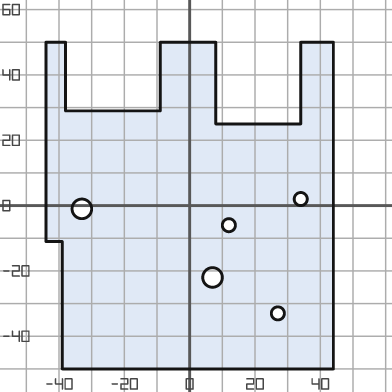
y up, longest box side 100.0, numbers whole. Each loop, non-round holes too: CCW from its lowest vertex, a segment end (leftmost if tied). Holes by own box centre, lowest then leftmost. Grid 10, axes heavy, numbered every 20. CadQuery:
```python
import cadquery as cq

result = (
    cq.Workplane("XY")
    .moveTo(-39.0, -50.0)
    .lineTo(44.0, -50.0)
    .lineTo(44.0, 50.0)
    .lineTo(34.0, 50.0)
    .lineTo(34.0, 25.0)
    .lineTo(8.0, 25.0)
    .lineTo(8.0, 50.0)
    .lineTo(-9.0, 50.0)
    .lineTo(-9.0, 29.0)
    .lineTo(-38.0, 29.0)
    .lineTo(-38.0, 50.0)
    .lineTo(-44.0, 50.0)
    .lineTo(-44.0, -11.0)
    .lineTo(-39.0, -11.0)
    .close()
    .moveTo(27.0, -33.0)
    .circle(2.0)
    .moveTo(7.0, -22.0)
    .circle(3.0)
    .moveTo(12.0, -6.0)
    .circle(2.0)
    .moveTo(-33.0, -1.0)
    .circle(3.0)
    .moveTo(34.0, 2.0)
    .circle(2.0)
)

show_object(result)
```